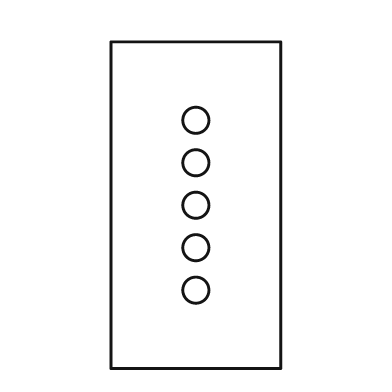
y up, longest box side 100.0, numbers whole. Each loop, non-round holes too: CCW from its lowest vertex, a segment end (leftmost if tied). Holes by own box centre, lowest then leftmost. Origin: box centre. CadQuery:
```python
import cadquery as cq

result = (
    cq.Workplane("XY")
    .moveTo(-26.0, -50.0)
    .lineTo(26.0, -50.0)
    .lineTo(26.0, 50.0)
    .lineTo(-26.0, 50.0)
    .close()
    .moveTo(0.0, -26.0)
    .circle(4.0)
    .moveTo(0.0, -13.0)
    .circle(4.0)
    .moveTo(0.0, 0.0)
    .circle(4.0)
    .moveTo(0.0, 13.0)
    .circle(4.0)
    .moveTo(0.0, 26.0)
    .circle(4.0)
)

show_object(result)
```